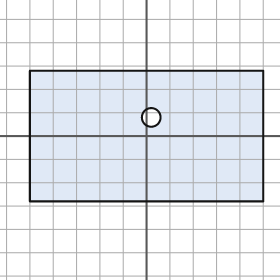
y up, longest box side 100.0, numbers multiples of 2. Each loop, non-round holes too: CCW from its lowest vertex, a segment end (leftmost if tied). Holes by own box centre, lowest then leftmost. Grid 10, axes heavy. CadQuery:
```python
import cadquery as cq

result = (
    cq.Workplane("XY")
    .moveTo(-50.0, -28.0)
    .lineTo(50.0, -28.0)
    .lineTo(50.0, 28.0)
    .lineTo(-50.0, 28.0)
    .close()
    .moveTo(2.0, 8.0)
    .circle(4.0)
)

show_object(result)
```